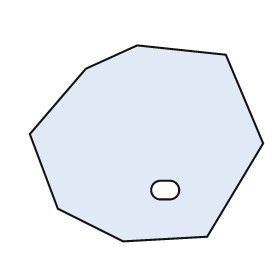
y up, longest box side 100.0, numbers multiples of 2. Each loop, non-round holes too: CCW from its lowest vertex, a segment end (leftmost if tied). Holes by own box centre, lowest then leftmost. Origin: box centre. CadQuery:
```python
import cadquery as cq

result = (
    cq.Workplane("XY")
    .moveTo(-10.0, -42.0)
    .lineTo(26.0, -40.0)
    .lineTo(50.0, 0.0)
    .lineTo(34.0, 38.0)
    .lineTo(-4.0, 42.0)
    .lineTo(-26.0, 32.0)
    .lineTo(-50.0, 4.0)
    .lineTo(-38.0, -28.0)
    .close()
    .moveTo(6.0, -24.0)
    .lineTo(10.0, -24.0)
    .threePointArc((14.0, -20.0), (10.0, -16.0))
    .lineTo(6.0, -16.0)
    .threePointArc((2.0, -20.0), (6.0, -24.0))
    .close()
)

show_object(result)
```